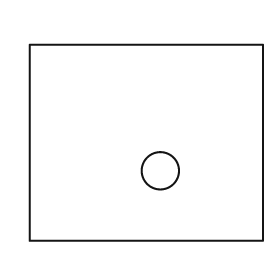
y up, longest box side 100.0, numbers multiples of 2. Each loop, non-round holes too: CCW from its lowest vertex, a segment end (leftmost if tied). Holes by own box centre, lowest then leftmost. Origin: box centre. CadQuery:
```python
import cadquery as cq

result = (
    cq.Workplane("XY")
    .moveTo(-50.0, -42.0)
    .lineTo(50.0, -42.0)
    .lineTo(50.0, 42.0)
    .lineTo(-50.0, 42.0)
    .close()
    .moveTo(6.0, -12.0)
    .circle(8.0)
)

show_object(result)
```